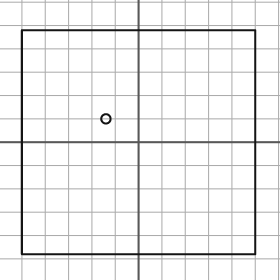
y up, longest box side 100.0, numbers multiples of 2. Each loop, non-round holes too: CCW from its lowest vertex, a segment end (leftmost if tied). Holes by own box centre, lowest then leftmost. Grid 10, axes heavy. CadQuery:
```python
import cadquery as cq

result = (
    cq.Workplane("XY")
    .moveTo(-50.0, -48.0)
    .lineTo(50.0, -48.0)
    .lineTo(50.0, 48.0)
    .lineTo(-50.0, 48.0)
    .close()
    .moveTo(-14.0, 10.0)
    .circle(2.0)
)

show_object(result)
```